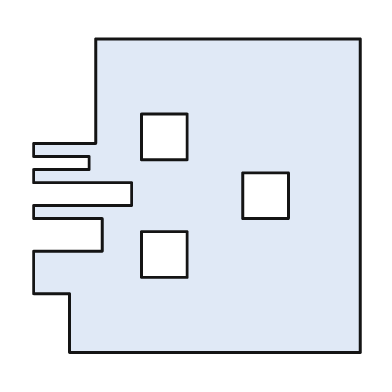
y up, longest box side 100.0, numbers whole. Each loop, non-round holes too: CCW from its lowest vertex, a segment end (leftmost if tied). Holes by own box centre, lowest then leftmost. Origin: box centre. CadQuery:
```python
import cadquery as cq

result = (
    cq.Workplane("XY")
    .moveTo(-39.0, -48.0)
    .lineTo(50.0, -48.0)
    .lineTo(50.0, 48.0)
    .lineTo(-31.0, 48.0)
    .lineTo(-31.0, 16.0)
    .lineTo(-50.0, 16.0)
    .lineTo(-50.0, 12.0)
    .lineTo(-33.0, 12.0)
    .lineTo(-33.0, 8.0)
    .lineTo(-50.0, 8.0)
    .lineTo(-50.0, 4.0)
    .lineTo(-20.0, 4.0)
    .lineTo(-20.0, -3.0)
    .lineTo(-50.0, -3.0)
    .lineTo(-50.0, -7.0)
    .lineTo(-29.0, -7.0)
    .lineTo(-29.0, -17.0)
    .lineTo(-50.0, -17.0)
    .lineTo(-50.0, -30.0)
    .lineTo(-39.0, -30.0)
    .close()
    .moveTo(-17.0, -25.0)
    .lineTo(-3.0, -25.0)
    .lineTo(-3.0, -11.0)
    .lineTo(-17.0, -11.0)
    .close()
    .moveTo(14.0, -7.0)
    .lineTo(28.0, -7.0)
    .lineTo(28.0, 7.0)
    .lineTo(14.0, 7.0)
    .close()
    .moveTo(-17.0, 11.0)
    .lineTo(-3.0, 11.0)
    .lineTo(-3.0, 25.0)
    .lineTo(-17.0, 25.0)
    .close()
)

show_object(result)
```